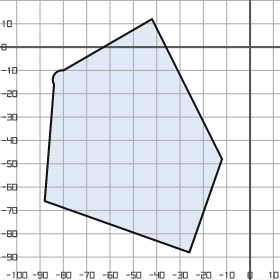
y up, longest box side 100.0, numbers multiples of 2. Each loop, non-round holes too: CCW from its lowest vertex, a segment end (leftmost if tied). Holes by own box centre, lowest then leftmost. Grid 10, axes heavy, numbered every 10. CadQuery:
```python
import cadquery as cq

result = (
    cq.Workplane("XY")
    .moveTo(-26.0, -88.0)
    .lineTo(-12.0, -48.0)
    .lineTo(-42.0, 12.0)
    .lineTo(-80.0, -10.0)
    .threePointArc((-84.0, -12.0), (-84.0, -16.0))
    .lineTo(-88.0, -66.0)
    .close()
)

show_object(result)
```